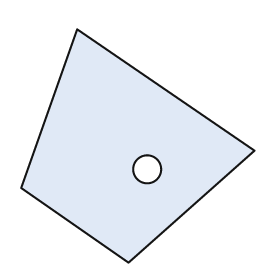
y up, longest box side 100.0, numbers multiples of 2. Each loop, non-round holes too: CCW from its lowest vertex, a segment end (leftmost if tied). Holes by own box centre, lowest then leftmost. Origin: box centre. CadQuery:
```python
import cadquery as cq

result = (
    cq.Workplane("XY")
    .moveTo(-4.0, -50.0)
    .lineTo(50.0, -2.0)
    .lineTo(-26.0, 50.0)
    .lineTo(-50.0, -18.0)
    .close()
    .moveTo(4.0, -10.0)
    .circle(6.0)
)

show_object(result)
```